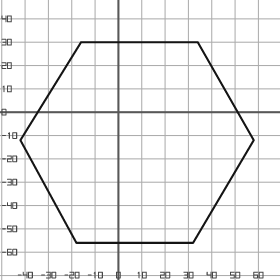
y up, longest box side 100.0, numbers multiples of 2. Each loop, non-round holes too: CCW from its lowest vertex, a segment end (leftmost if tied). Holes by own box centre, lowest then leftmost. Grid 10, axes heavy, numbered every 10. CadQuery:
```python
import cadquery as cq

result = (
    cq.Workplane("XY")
    .moveTo(-18.0, -56.0)
    .lineTo(32.0, -56.0)
    .lineTo(58.0, -12.0)
    .lineTo(34.0, 30.0)
    .lineTo(-16.0, 30.0)
    .lineTo(-42.0, -12.0)
    .close()
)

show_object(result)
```